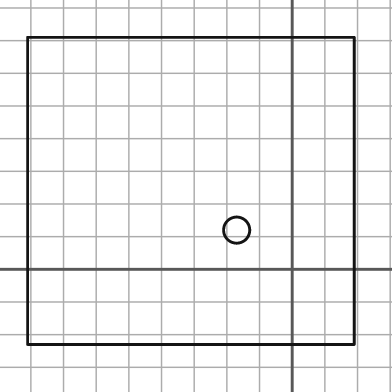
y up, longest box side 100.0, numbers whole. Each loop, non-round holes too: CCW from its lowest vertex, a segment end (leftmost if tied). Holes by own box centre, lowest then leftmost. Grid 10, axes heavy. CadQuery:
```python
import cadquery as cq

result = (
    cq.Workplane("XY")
    .moveTo(-81.0, -23.0)
    .lineTo(19.0, -23.0)
    .lineTo(19.0, 71.0)
    .lineTo(-81.0, 71.0)
    .close()
    .moveTo(-17.0, 12.0)
    .circle(4.0)
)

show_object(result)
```